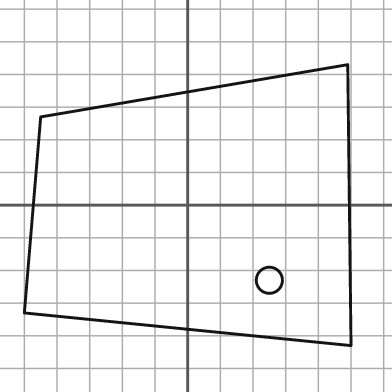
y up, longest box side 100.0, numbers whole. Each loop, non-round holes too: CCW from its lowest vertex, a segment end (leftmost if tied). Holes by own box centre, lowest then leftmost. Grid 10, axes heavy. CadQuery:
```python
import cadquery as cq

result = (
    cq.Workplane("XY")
    .moveTo(50.0, -43.0)
    .lineTo(49.0, 43.0)
    .lineTo(-45.0, 27.0)
    .lineTo(-50.0, -33.0)
    .close()
    .moveTo(25.0, -23.0)
    .circle(4.0)
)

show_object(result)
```